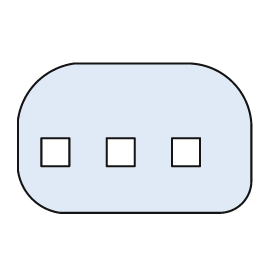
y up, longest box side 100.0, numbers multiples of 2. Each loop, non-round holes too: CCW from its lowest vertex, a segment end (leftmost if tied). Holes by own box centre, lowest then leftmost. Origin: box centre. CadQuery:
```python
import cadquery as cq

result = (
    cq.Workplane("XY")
    .moveTo(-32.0, -32.0)
    .lineTo(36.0, -32.0)
    .threePointArc((46.0, -28.0), (50.0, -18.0))
    .lineTo(50.0, 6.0)
    .threePointArc((42.0, 24.0), (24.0, 32.0))
    .lineTo(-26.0, 32.0)
    .threePointArc((-42.0, 24.0), (-50.0, 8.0))
    .lineTo(-50.0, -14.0)
    .threePointArc((-44.0, -26.0), (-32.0, -32.0))
    .close()
    .moveTo(-40.0, -12.0)
    .lineTo(-28.0, -12.0)
    .lineTo(-28.0, 0.0)
    .lineTo(-40.0, 0.0)
    .close()
    .moveTo(-12.0, -12.0)
    .lineTo(0.0, -12.0)
    .lineTo(0.0, 0.0)
    .lineTo(-12.0, 0.0)
    .close()
    .moveTo(16.0, -12.0)
    .lineTo(28.0, -12.0)
    .lineTo(28.0, 0.0)
    .lineTo(16.0, 0.0)
    .close()
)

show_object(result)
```